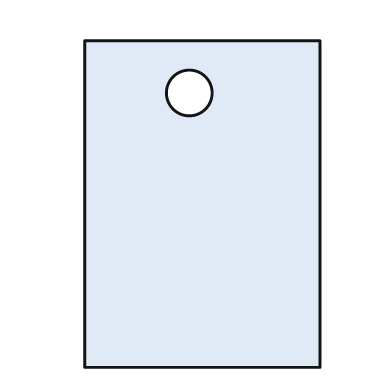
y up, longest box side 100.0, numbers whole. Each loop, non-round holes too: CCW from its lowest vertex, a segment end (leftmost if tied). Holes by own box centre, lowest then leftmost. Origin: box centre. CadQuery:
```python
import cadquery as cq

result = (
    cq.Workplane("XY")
    .moveTo(-36.0, -50.0)
    .lineTo(36.0, -50.0)
    .lineTo(36.0, 50.0)
    .lineTo(-36.0, 50.0)
    .close()
    .moveTo(-4.0, 34.0)
    .circle(7.0)
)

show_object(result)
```